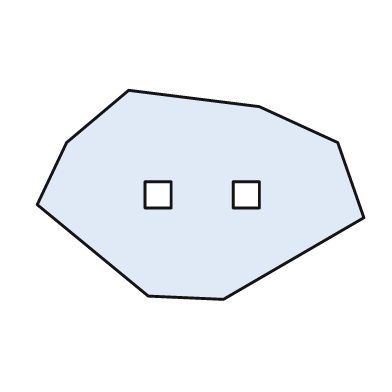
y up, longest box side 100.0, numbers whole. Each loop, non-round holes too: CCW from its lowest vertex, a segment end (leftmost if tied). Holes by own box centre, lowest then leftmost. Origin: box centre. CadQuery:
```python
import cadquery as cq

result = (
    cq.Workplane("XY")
    .moveTo(7.0, -32.0)
    .lineTo(50.0, -7.0)
    .lineTo(42.0, 16.0)
    .lineTo(18.0, 27.0)
    .lineTo(-22.0, 32.0)
    .lineTo(-41.0, 16.0)
    .lineTo(-50.0, -3.0)
    .lineTo(-16.0, -31.0)
    .close()
    .moveTo(-17.0, -4.0)
    .lineTo(-9.0, -4.0)
    .lineTo(-9.0, 4.0)
    .lineTo(-17.0, 4.0)
    .close()
    .moveTo(10.0, -4.0)
    .lineTo(18.0, -4.0)
    .lineTo(18.0, 4.0)
    .lineTo(10.0, 4.0)
    .close()
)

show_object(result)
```